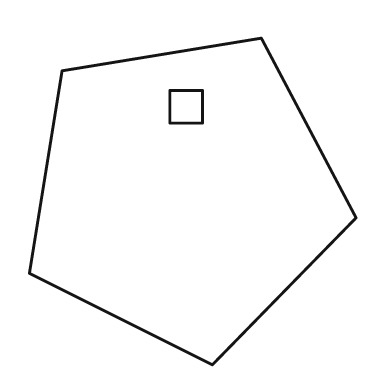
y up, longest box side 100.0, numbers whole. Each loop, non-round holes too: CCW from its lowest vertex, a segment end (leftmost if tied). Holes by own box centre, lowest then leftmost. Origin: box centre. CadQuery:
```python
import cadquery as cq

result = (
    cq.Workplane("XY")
    .moveTo(6.0, -50.0)
    .lineTo(50.0, -5.0)
    .lineTo(21.0, 50.0)
    .lineTo(-40.0, 40.0)
    .lineTo(-50.0, -22.0)
    .close()
    .moveTo(-7.0, 24.0)
    .lineTo(3.0, 24.0)
    .lineTo(3.0, 34.0)
    .lineTo(-7.0, 34.0)
    .close()
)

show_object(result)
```